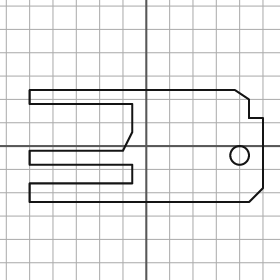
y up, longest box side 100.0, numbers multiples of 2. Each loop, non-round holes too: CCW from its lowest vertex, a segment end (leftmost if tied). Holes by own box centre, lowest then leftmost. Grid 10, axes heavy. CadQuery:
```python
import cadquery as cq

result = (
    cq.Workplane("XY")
    .moveTo(-50.0, -24.0)
    .lineTo(44.0, -24.0)
    .lineTo(50.0, -18.0)
    .lineTo(50.0, 12.0)
    .lineTo(44.0, 12.0)
    .lineTo(44.0, 20.0)
    .lineTo(38.0, 24.0)
    .lineTo(-50.0, 24.0)
    .lineTo(-50.0, 18.0)
    .lineTo(-6.0, 18.0)
    .lineTo(-6.0, 6.0)
    .lineTo(-10.0, -2.0)
    .lineTo(-50.0, -2.0)
    .lineTo(-50.0, -8.0)
    .lineTo(-6.0, -8.0)
    .lineTo(-6.0, -16.0)
    .lineTo(-50.0, -16.0)
    .close()
    .moveTo(40.0, -4.0)
    .circle(4.0)
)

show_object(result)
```